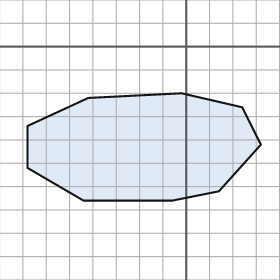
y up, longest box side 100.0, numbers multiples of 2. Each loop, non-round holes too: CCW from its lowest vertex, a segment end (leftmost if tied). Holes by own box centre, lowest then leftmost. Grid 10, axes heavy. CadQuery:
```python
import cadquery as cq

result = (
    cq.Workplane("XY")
    .moveTo(-44.0, -66.0)
    .lineTo(-6.0, -66.0)
    .lineTo(14.0, -62.0)
    .lineTo(32.0, -42.0)
    .lineTo(24.0, -26.0)
    .lineTo(-2.0, -20.0)
    .lineTo(-42.0, -22.0)
    .lineTo(-68.0, -34.0)
    .lineTo(-68.0, -52.0)
    .close()
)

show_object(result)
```